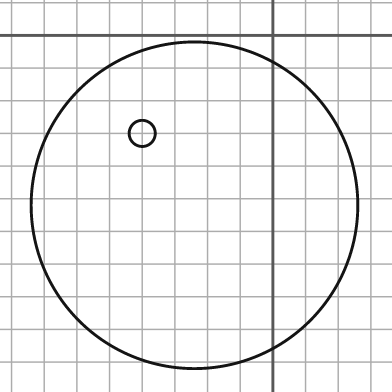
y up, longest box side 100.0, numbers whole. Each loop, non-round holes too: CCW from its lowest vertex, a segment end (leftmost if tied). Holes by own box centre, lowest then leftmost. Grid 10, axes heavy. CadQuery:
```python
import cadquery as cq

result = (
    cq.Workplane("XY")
    .moveTo(-24.0, -52.0)
    .circle(50.0)
    .moveTo(-40.0, -30.0)
    .circle(4.0)
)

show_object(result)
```